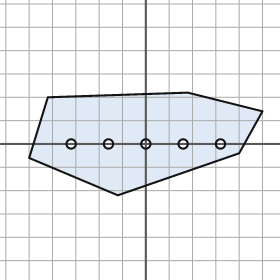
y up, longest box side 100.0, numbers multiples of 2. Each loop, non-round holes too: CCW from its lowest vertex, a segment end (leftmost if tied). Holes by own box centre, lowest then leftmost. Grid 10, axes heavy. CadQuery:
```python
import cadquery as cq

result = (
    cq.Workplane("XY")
    .moveTo(-12.0, -22.0)
    .lineTo(40.0, -4.0)
    .lineTo(50.0, 14.0)
    .lineTo(18.0, 22.0)
    .lineTo(-42.0, 20.0)
    .lineTo(-50.0, -6.0)
    .close()
    .moveTo(-32.0, 0.0)
    .circle(2.0)
    .moveTo(-16.0, 0.0)
    .circle(2.0)
    .moveTo(0.0, 0.0)
    .circle(2.0)
    .moveTo(16.0, 0.0)
    .circle(2.0)
    .moveTo(32.0, 0.0)
    .circle(2.0)
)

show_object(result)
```